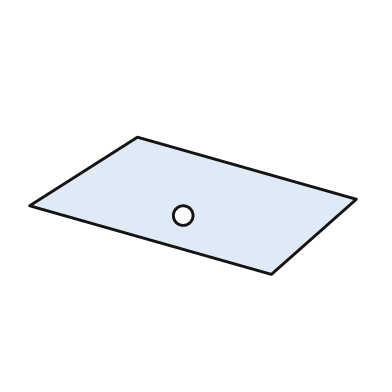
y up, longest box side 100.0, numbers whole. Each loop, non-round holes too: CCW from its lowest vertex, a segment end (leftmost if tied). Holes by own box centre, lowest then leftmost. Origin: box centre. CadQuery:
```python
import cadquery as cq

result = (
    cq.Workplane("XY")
    .moveTo(24.0, -21.0)
    .lineTo(50.0, 2.0)
    .lineTo(-17.0, 21.0)
    .lineTo(-50.0, 0.0)
    .close()
    .moveTo(-3.0, -3.0)
    .circle(3.0)
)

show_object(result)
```